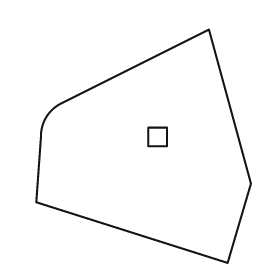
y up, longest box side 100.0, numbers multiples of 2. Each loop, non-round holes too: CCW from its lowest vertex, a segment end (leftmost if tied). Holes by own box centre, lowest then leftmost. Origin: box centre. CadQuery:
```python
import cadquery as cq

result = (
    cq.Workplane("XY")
    .moveTo(36.0, -50.0)
    .lineTo(46.0, -16.0)
    .lineTo(28.0, 50.0)
    .lineTo(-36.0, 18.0)
    .threePointArc((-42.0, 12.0), (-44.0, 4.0))
    .lineTo(-46.0, -24.0)
    .close()
    .moveTo(2.0, 0.0)
    .lineTo(10.0, 0.0)
    .lineTo(10.0, 8.0)
    .lineTo(2.0, 8.0)
    .close()
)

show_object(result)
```